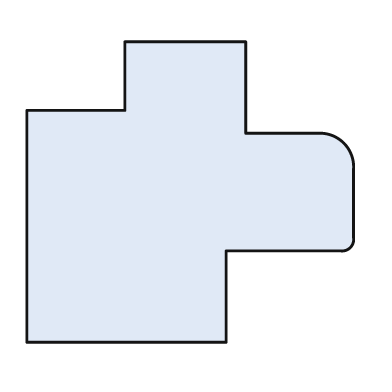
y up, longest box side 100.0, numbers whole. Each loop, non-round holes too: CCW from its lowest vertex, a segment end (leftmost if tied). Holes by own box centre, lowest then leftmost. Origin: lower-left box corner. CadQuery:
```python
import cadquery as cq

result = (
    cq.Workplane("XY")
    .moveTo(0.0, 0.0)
    .lineTo(61.0, 0.0)
    .lineTo(61.0, 28.0)
    .lineTo(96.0, 28.0)
    .threePointArc((99.0, 29.0), (100.0, 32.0))
    .lineTo(100.0, 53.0)
    .threePointArc((97.0, 61.0), (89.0, 64.0))
    .lineTo(67.0, 64.0)
    .lineTo(67.0, 92.0)
    .lineTo(30.0, 92.0)
    .lineTo(30.0, 71.0)
    .lineTo(0.0, 71.0)
    .close()
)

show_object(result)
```